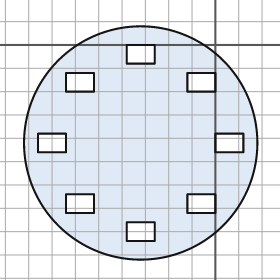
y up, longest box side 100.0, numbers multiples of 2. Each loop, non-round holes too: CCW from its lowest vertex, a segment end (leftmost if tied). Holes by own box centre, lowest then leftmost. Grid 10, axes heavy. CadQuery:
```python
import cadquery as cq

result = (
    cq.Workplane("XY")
    .moveTo(-32.0, -42.0)
    .circle(50.0)
    .moveTo(-38.0, -84.0)
    .lineTo(-26.0, -84.0)
    .lineTo(-26.0, -76.0)
    .lineTo(-38.0, -76.0)
    .close()
    .moveTo(-64.0, -72.0)
    .lineTo(-52.0, -72.0)
    .lineTo(-52.0, -64.0)
    .lineTo(-64.0, -64.0)
    .close()
    .moveTo(-12.0, -72.0)
    .lineTo(0.0, -72.0)
    .lineTo(0.0, -64.0)
    .lineTo(-12.0, -64.0)
    .close()
    .moveTo(-76.0, -46.0)
    .lineTo(-64.0, -46.0)
    .lineTo(-64.0, -38.0)
    .lineTo(-76.0, -38.0)
    .close()
    .moveTo(0.0, -46.0)
    .lineTo(12.0, -46.0)
    .lineTo(12.0, -38.0)
    .lineTo(0.0, -38.0)
    .close()
    .moveTo(-64.0, -20.0)
    .lineTo(-52.0, -20.0)
    .lineTo(-52.0, -12.0)
    .lineTo(-64.0, -12.0)
    .close()
    .moveTo(-12.0, -20.0)
    .lineTo(0.0, -20.0)
    .lineTo(0.0, -12.0)
    .lineTo(-12.0, -12.0)
    .close()
    .moveTo(-38.0, -8.0)
    .lineTo(-26.0, -8.0)
    .lineTo(-26.0, 0.0)
    .lineTo(-38.0, 0.0)
    .close()
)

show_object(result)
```